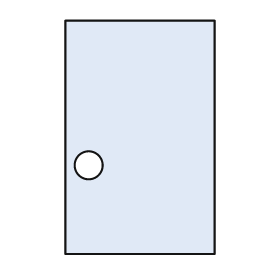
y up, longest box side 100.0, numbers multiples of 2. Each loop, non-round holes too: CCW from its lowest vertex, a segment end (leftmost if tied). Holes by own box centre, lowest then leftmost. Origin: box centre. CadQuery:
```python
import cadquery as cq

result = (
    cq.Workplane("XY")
    .moveTo(-32.0, -50.0)
    .lineTo(32.0, -50.0)
    .lineTo(32.0, 50.0)
    .lineTo(-32.0, 50.0)
    .close()
    .moveTo(-22.0, -12.0)
    .circle(6.0)
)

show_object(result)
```